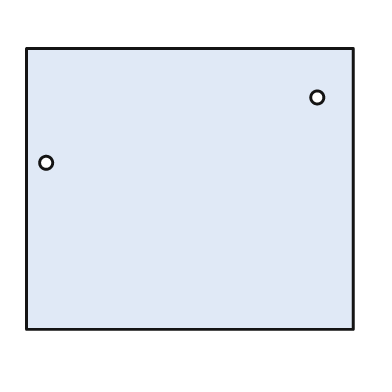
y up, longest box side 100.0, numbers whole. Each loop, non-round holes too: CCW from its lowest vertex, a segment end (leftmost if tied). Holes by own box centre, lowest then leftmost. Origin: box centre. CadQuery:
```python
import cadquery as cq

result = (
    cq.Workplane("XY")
    .moveTo(-50.0, -43.0)
    .lineTo(50.0, -43.0)
    .lineTo(50.0, 43.0)
    .lineTo(-50.0, 43.0)
    .close()
    .moveTo(-44.0, 8.0)
    .circle(2.0)
    .moveTo(39.0, 28.0)
    .circle(2.0)
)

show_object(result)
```